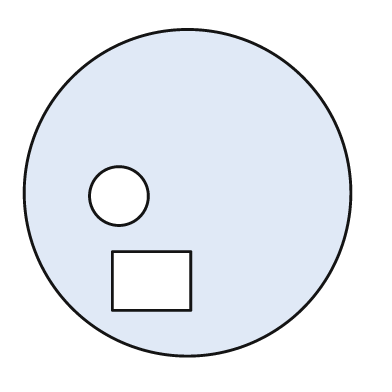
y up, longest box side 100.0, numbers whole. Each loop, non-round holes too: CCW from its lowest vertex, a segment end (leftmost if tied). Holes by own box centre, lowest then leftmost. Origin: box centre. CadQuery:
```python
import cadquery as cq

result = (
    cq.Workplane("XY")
    .moveTo(0.0, 0.0)
    .circle(50.0)
    .moveTo(-23.0, -36.0)
    .lineTo(1.0, -36.0)
    .lineTo(1.0, -18.0)
    .lineTo(-23.0, -18.0)
    .close()
    .moveTo(-21.0, -1.0)
    .circle(9.0)
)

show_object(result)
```